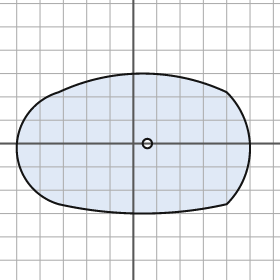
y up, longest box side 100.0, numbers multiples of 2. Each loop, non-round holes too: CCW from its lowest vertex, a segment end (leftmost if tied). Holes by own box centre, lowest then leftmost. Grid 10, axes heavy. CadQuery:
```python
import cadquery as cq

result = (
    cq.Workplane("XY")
    .moveTo(-32.0, -26.0)
    .threePointArc((4.0, -30.0), (40.0, -26.0))
    .threePointArc((50.0, -2.0), (40.0, 22.0))
    .threePointArc((4.0, 30.0), (-32.0, 22.0))
    .threePointArc((-50.0, -2.0), (-32.0, -26.0))
    .close()
    .moveTo(6.0, 0.0)
    .circle(2.0)
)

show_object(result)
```